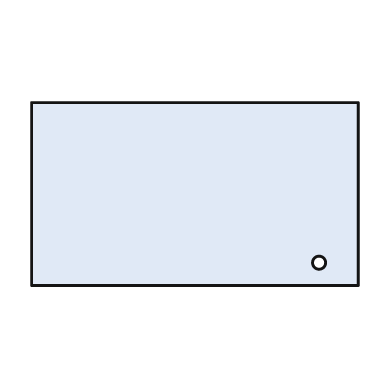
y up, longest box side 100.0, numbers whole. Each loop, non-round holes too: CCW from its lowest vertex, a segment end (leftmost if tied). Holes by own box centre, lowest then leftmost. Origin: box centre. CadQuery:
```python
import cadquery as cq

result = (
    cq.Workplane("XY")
    .moveTo(-50.0, -28.0)
    .lineTo(50.0, -28.0)
    .lineTo(50.0, 28.0)
    .lineTo(-50.0, 28.0)
    .close()
    .moveTo(38.0, -21.0)
    .circle(2.0)
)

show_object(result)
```